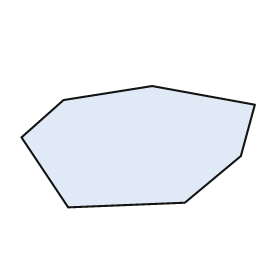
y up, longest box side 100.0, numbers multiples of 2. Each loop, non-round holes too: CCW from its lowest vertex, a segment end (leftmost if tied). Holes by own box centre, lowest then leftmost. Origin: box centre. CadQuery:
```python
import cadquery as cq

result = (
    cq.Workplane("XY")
    .moveTo(-30.0, -26.0)
    .lineTo(20.0, -24.0)
    .lineTo(44.0, -4.0)
    .lineTo(50.0, 18.0)
    .lineTo(6.0, 26.0)
    .lineTo(-32.0, 20.0)
    .lineTo(-50.0, 4.0)
    .close()
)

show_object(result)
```